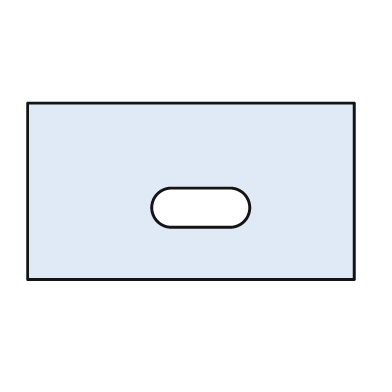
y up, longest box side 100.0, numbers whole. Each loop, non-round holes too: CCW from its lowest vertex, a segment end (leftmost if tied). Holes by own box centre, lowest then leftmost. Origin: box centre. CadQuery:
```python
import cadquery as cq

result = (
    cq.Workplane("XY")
    .moveTo(-50.0, -27.0)
    .lineTo(50.0, -27.0)
    .lineTo(50.0, 27.0)
    .lineTo(-50.0, 27.0)
    .close()
    .moveTo(-6.0, -11.0)
    .lineTo(12.0, -11.0)
    .threePointArc((18.0, -5.0), (12.0, 1.0))
    .lineTo(-6.0, 1.0)
    .threePointArc((-12.0, -5.0), (-6.0, -11.0))
    .close()
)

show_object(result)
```